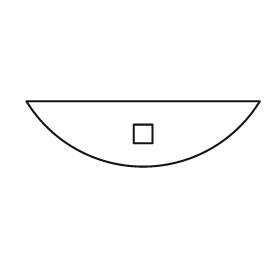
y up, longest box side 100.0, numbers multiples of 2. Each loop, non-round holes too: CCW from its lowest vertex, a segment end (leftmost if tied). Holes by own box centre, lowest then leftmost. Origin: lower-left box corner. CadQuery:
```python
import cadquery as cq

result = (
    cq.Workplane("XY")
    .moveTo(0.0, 28.0)
    .threePointArc((50.0, 0.0), (100.0, 28.0))
    .close()
    .moveTo(46.0, 10.0)
    .lineTo(54.0, 10.0)
    .lineTo(54.0, 18.0)
    .lineTo(46.0, 18.0)
    .close()
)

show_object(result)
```